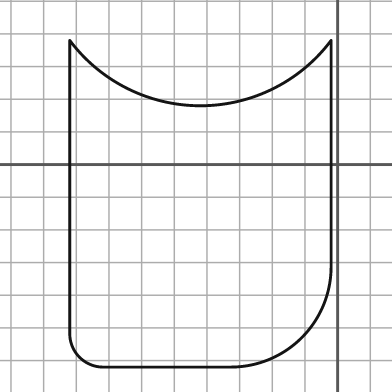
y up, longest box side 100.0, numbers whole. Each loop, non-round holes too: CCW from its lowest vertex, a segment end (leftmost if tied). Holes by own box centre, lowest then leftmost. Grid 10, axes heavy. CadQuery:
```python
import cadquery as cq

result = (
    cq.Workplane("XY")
    .moveTo(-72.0, -62.0)
    .lineTo(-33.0, -62.0)
    .threePointArc((-11.0, -53.0), (-2.0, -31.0))
    .lineTo(-2.0, 38.0)
    .threePointArc((-42.0, 18.0), (-82.0, 38.0))
    .lineTo(-82.0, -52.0)
    .threePointArc((-79.0, -59.0), (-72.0, -62.0))
    .close()
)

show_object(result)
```